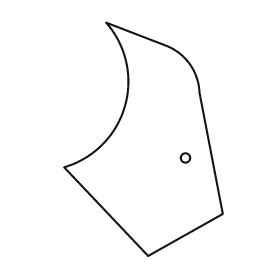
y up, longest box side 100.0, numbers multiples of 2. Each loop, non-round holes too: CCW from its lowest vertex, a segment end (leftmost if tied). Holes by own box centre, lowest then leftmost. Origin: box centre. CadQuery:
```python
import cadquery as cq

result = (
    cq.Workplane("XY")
    .moveTo(2.0, -50.0)
    .lineTo(34.0, -32.0)
    .lineTo(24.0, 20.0)
    .threePointArc((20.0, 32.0), (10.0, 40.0))
    .lineTo(-16.0, 50.0)
    .threePointArc((-8.0, 14.0), (-34.0, -12.0))
    .close()
    .moveTo(18.0, -8.0)
    .circle(2.0)
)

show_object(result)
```